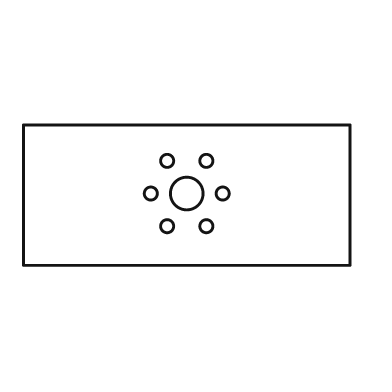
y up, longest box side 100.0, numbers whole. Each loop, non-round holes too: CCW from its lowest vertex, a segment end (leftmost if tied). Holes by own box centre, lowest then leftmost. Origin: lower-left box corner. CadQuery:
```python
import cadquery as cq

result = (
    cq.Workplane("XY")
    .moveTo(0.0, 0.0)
    .lineTo(100.0, 0.0)
    .lineTo(100.0, 43.0)
    .lineTo(0.0, 43.0)
    .close()
    .moveTo(44.0, 12.0)
    .circle(2.0)
    .moveTo(56.0, 12.0)
    .circle(2.0)
    .moveTo(39.0, 22.0)
    .circle(2.0)
    .moveTo(50.0, 22.0)
    .circle(5.0)
    .moveTo(61.0, 22.0)
    .circle(2.0)
    .moveTo(44.0, 32.0)
    .circle(2.0)
    .moveTo(56.0, 32.0)
    .circle(2.0)
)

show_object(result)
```